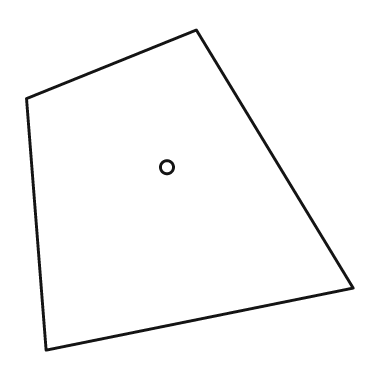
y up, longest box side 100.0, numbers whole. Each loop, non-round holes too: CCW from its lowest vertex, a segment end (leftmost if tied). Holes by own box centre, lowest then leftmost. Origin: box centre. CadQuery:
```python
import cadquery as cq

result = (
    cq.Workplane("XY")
    .moveTo(-44.0, -49.0)
    .lineTo(50.0, -30.0)
    .lineTo(2.0, 49.0)
    .lineTo(-50.0, 28.0)
    .close()
    .moveTo(-7.0, 7.0)
    .circle(2.0)
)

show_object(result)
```